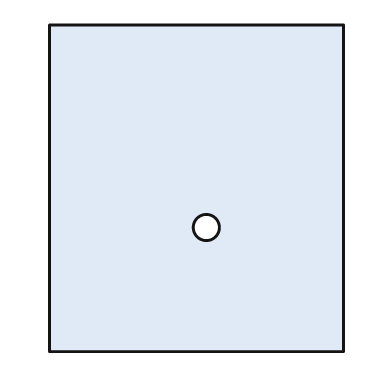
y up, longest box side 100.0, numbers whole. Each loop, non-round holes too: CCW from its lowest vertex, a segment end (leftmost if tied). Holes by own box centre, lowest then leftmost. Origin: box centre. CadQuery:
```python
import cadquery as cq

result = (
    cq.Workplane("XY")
    .moveTo(-45.0, -50.0)
    .lineTo(45.0, -50.0)
    .lineTo(45.0, 50.0)
    .lineTo(-45.0, 50.0)
    .close()
    .moveTo(3.0, -12.0)
    .circle(4.0)
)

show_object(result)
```